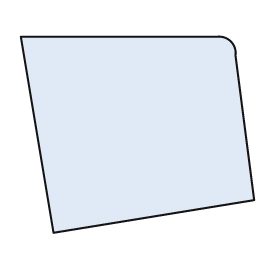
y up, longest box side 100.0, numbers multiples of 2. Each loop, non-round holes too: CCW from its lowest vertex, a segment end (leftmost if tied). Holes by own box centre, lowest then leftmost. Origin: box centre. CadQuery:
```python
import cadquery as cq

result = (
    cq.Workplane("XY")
    .moveTo(-36.0, -42.0)
    .lineTo(50.0, -28.0)
    .lineTo(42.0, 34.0)
    .threePointArc((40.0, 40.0), (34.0, 42.0))
    .lineTo(-50.0, 42.0)
    .close()
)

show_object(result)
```